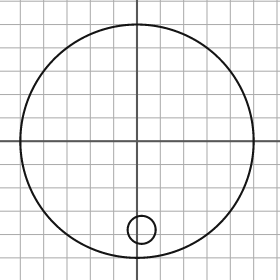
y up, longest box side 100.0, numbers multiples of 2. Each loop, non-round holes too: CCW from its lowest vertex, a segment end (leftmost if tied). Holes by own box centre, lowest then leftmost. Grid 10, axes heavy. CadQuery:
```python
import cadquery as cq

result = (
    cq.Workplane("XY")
    .moveTo(0.0, 0.0)
    .circle(50.0)
    .moveTo(2.0, -38.0)
    .circle(6.0)
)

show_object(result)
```